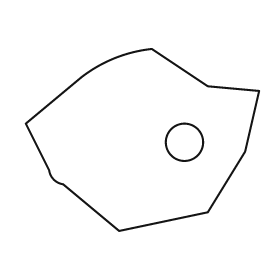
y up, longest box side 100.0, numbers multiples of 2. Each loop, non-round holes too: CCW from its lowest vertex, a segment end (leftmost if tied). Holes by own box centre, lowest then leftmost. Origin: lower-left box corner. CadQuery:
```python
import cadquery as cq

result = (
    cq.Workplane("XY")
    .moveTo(40.0, 0.0)
    .lineTo(78.0, 8.0)
    .lineTo(94.0, 34.0)
    .lineTo(100.0, 60.0)
    .lineTo(78.0, 62.0)
    .lineTo(54.0, 78.0)
    .threePointArc((38.0, 74.0), (24.0, 66.0))
    .lineTo(0.0, 46.0)
    .lineTo(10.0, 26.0)
    .threePointArc((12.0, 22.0), (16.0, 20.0))
    .close()
    .moveTo(68.0, 38.0)
    .circle(8.0)
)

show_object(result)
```